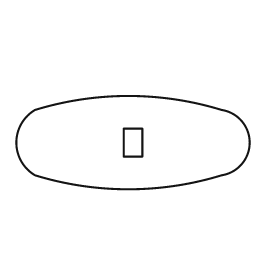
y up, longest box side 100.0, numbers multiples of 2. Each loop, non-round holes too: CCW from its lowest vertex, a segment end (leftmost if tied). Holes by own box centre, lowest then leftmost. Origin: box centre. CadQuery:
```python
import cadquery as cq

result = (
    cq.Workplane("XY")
    .moveTo(-42.0, -14.0)
    .threePointArc((-2.0, -20.0), (38.0, -14.0))
    .threePointArc((50.0, 0.0), (38.0, 14.0))
    .threePointArc((-2.0, 20.0), (-42.0, 14.0))
    .threePointArc((-50.0, 0.0), (-42.0, -14.0))
    .close()
    .moveTo(-4.0, -6.0)
    .lineTo(4.0, -6.0)
    .lineTo(4.0, 6.0)
    .lineTo(-4.0, 6.0)
    .close()
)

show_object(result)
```